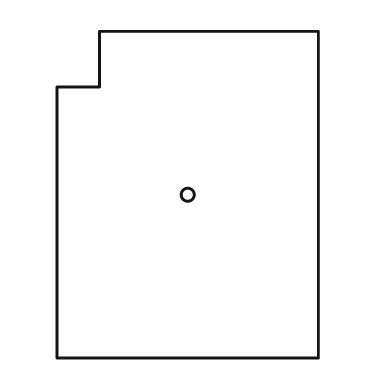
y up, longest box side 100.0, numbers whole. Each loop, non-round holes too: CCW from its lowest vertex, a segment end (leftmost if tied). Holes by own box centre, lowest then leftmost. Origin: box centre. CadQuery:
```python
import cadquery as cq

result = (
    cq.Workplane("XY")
    .moveTo(-40.0, -50.0)
    .lineTo(40.0, -50.0)
    .lineTo(40.0, 50.0)
    .lineTo(-27.0, 50.0)
    .lineTo(-27.0, 33.0)
    .lineTo(-40.0, 33.0)
    .close()
    .moveTo(0.0, 0.0)
    .circle(2.0)
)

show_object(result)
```